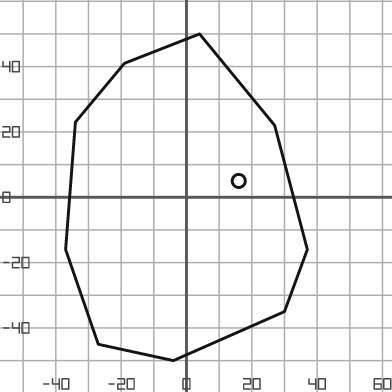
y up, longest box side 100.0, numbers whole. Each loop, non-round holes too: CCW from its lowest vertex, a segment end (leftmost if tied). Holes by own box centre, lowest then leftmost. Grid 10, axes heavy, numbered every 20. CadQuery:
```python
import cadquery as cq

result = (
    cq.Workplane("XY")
    .moveTo(-4.0, -50.0)
    .lineTo(30.0, -35.0)
    .lineTo(37.0, -16.0)
    .lineTo(27.0, 22.0)
    .lineTo(4.0, 50.0)
    .lineTo(-19.0, 41.0)
    .lineTo(-34.0, 23.0)
    .lineTo(-37.0, -16.0)
    .lineTo(-27.0, -45.0)
    .close()
    .moveTo(16.0, 5.0)
    .circle(2.0)
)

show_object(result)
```